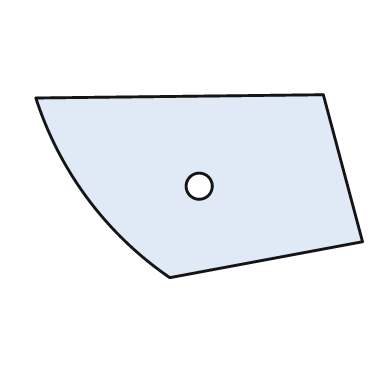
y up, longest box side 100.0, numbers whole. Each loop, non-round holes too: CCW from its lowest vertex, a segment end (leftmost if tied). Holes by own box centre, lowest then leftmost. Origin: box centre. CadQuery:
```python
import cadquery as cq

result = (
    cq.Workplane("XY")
    .moveTo(-9.0, -28.0)
    .lineTo(50.0, -17.0)
    .lineTo(38.0, 28.0)
    .lineTo(-50.0, 27.0)
    .threePointArc((-34.0, -4.0), (-9.0, -28.0))
    .close()
    .moveTo(0.0, 0.0)
    .circle(4.0)
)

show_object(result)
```